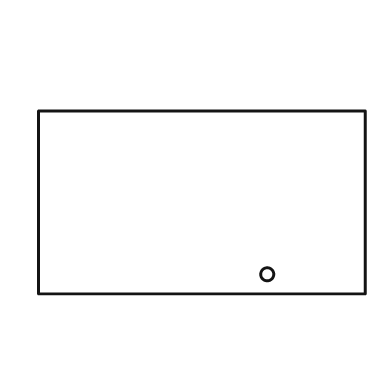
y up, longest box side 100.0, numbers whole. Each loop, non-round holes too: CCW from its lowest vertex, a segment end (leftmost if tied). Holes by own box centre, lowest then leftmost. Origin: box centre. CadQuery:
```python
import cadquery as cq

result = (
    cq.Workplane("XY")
    .moveTo(-50.0, -28.0)
    .lineTo(50.0, -28.0)
    .lineTo(50.0, 28.0)
    .lineTo(-50.0, 28.0)
    .close()
    .moveTo(20.0, -22.0)
    .circle(2.0)
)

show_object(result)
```